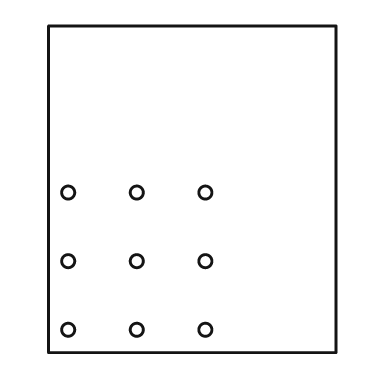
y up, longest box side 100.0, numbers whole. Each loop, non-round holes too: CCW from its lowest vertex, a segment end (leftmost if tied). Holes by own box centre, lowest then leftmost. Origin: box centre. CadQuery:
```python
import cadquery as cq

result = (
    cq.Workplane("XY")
    .moveTo(-44.0, -50.0)
    .lineTo(44.0, -50.0)
    .lineTo(44.0, 50.0)
    .lineTo(-44.0, 50.0)
    .close()
    .moveTo(-38.0, -43.0)
    .circle(2.0)
    .moveTo(-17.0, -43.0)
    .circle(2.0)
    .moveTo(4.0, -43.0)
    .circle(2.0)
    .moveTo(-38.0, -22.0)
    .circle(2.0)
    .moveTo(-17.0, -22.0)
    .circle(2.0)
    .moveTo(4.0, -22.0)
    .circle(2.0)
    .moveTo(-38.0, -1.0)
    .circle(2.0)
    .moveTo(-17.0, -1.0)
    .circle(2.0)
    .moveTo(4.0, -1.0)
    .circle(2.0)
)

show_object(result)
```